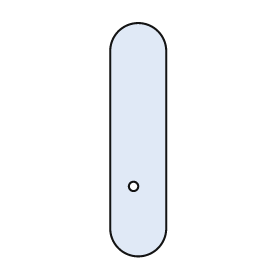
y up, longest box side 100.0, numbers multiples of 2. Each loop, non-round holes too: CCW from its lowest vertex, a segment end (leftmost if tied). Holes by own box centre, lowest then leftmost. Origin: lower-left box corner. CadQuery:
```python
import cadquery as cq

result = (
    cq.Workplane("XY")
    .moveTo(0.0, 12.0)
    .threePointArc((12.0, 0.0), (24.0, 12.0))
    .lineTo(24.0, 88.0)
    .threePointArc((12.0, 100.0), (0.0, 88.0))
    .close()
    .moveTo(10.0, 30.0)
    .circle(2.0)
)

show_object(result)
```